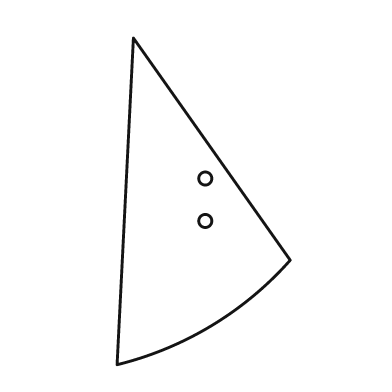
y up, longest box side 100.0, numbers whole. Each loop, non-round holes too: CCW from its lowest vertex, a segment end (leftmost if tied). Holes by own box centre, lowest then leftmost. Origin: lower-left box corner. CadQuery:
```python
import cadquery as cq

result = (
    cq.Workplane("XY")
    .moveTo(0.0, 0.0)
    .threePointArc((29.0, 12.0), (53.0, 32.0))
    .lineTo(5.0, 100.0)
    .close()
    .moveTo(27.0, 44.0)
    .circle(2.0)
    .moveTo(27.0, 57.0)
    .circle(2.0)
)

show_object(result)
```